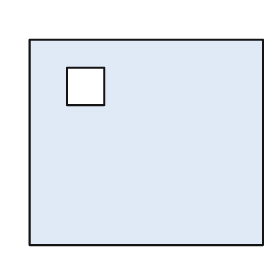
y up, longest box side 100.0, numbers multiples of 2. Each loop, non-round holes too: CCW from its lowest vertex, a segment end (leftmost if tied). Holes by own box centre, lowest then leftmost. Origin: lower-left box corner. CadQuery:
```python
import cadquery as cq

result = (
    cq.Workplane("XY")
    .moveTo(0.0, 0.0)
    .lineTo(100.0, 0.0)
    .lineTo(100.0, 88.0)
    .lineTo(0.0, 88.0)
    .close()
    .moveTo(16.0, 60.0)
    .lineTo(32.0, 60.0)
    .lineTo(32.0, 76.0)
    .lineTo(16.0, 76.0)
    .close()
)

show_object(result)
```